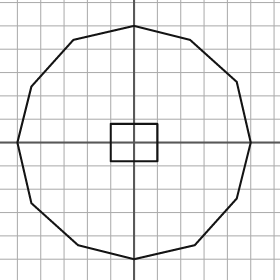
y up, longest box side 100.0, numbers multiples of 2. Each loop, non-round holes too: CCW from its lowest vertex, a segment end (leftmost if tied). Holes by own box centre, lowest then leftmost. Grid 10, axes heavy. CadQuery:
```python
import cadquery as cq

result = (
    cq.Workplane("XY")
    .moveTo(0.0, -50.0)
    .lineTo(26.0, -44.0)
    .lineTo(44.0, -24.0)
    .lineTo(50.0, 0.0)
    .lineTo(44.0, 26.0)
    .lineTo(24.0, 44.0)
    .lineTo(0.0, 50.0)
    .lineTo(-26.0, 44.0)
    .lineTo(-44.0, 24.0)
    .lineTo(-50.0, 0.0)
    .lineTo(-44.0, -26.0)
    .lineTo(-24.0, -44.0)
    .close()
    .moveTo(-10.0, -8.0)
    .lineTo(10.0, -8.0)
    .lineTo(10.0, 8.0)
    .lineTo(-10.0, 8.0)
    .close()
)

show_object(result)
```